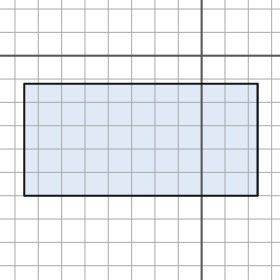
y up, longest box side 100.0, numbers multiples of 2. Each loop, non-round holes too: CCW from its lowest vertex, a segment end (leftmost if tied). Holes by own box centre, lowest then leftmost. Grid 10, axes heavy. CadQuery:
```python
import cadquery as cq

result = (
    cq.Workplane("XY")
    .moveTo(-76.0, -60.0)
    .lineTo(24.0, -60.0)
    .lineTo(24.0, -12.0)
    .lineTo(-76.0, -12.0)
    .close()
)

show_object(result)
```